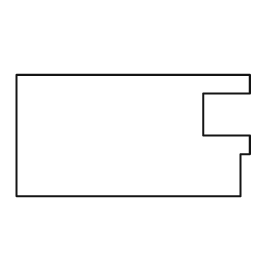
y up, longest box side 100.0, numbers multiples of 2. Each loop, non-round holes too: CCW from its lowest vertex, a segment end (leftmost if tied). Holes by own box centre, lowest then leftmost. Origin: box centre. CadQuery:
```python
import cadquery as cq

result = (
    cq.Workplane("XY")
    .moveTo(-50.0, -26.0)
    .lineTo(46.0, -26.0)
    .lineTo(46.0, -8.0)
    .lineTo(50.0, -8.0)
    .lineTo(50.0, 0.0)
    .lineTo(30.0, 0.0)
    .lineTo(30.0, 18.0)
    .lineTo(50.0, 18.0)
    .lineTo(50.0, 26.0)
    .lineTo(-50.0, 26.0)
    .close()
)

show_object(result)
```